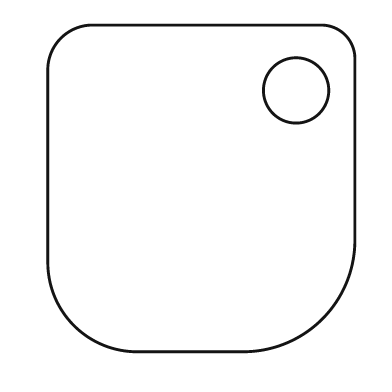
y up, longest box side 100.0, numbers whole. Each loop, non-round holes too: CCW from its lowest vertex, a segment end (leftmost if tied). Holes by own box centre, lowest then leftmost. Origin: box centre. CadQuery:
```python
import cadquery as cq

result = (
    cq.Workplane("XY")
    .moveTo(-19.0, -50.0)
    .lineTo(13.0, -50.0)
    .threePointArc((37.0, -40.0), (47.0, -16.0))
    .lineTo(47.0, 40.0)
    .threePointArc((44.0, 47.0), (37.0, 50.0))
    .lineTo(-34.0, 50.0)
    .threePointArc((-43.0, 46.0), (-47.0, 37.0))
    .lineTo(-47.0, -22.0)
    .threePointArc((-39.0, -42.0), (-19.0, -50.0))
    .close()
    .moveTo(29.0, 30.0)
    .circle(10.0)
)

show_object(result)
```